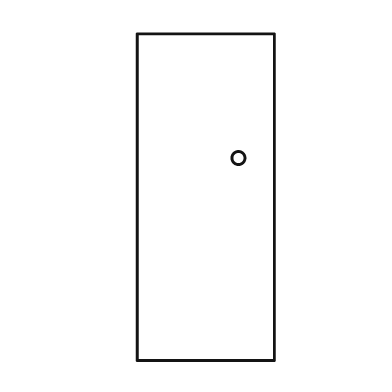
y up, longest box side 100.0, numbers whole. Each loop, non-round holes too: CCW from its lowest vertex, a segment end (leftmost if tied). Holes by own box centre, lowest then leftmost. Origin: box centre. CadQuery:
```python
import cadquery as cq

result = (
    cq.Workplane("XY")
    .moveTo(-21.0, -50.0)
    .lineTo(21.0, -50.0)
    .lineTo(21.0, 50.0)
    .lineTo(-21.0, 50.0)
    .close()
    .moveTo(10.0, 12.0)
    .circle(2.0)
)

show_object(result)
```